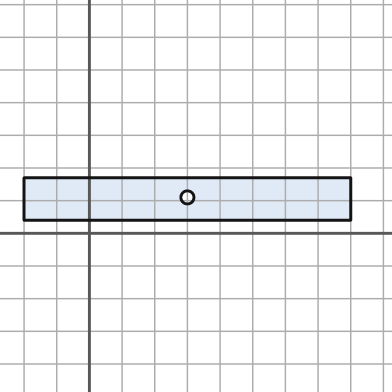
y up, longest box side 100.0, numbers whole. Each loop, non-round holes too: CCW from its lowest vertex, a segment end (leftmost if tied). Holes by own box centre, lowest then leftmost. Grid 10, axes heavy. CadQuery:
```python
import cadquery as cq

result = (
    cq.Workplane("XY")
    .moveTo(-20.0, 4.0)
    .lineTo(80.0, 4.0)
    .lineTo(80.0, 17.0)
    .lineTo(-20.0, 17.0)
    .close()
    .moveTo(30.0, 11.0)
    .circle(2.0)
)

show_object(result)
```